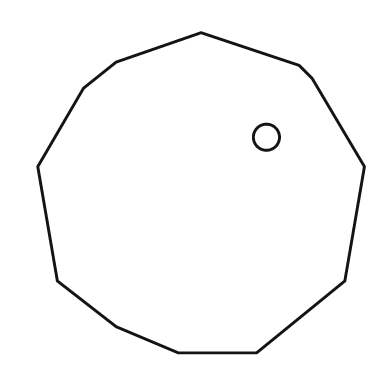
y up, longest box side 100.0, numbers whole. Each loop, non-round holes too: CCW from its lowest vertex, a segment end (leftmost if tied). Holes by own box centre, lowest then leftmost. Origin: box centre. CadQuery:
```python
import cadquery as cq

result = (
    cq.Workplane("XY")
    .moveTo(-7.0, -49.0)
    .lineTo(17.0, -49.0)
    .lineTo(44.0, -27.0)
    .lineTo(50.0, 8.0)
    .lineTo(34.0, 35.0)
    .lineTo(30.0, 39.0)
    .lineTo(0.0, 49.0)
    .lineTo(-26.0, 40.0)
    .lineTo(-36.0, 32.0)
    .lineTo(-50.0, 8.0)
    .lineTo(-44.0, -27.0)
    .lineTo(-26.0, -41.0)
    .close()
    .moveTo(20.0, 17.0)
    .circle(4.0)
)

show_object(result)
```